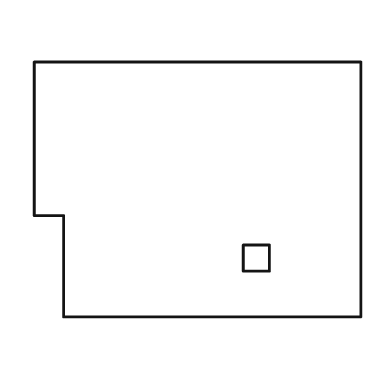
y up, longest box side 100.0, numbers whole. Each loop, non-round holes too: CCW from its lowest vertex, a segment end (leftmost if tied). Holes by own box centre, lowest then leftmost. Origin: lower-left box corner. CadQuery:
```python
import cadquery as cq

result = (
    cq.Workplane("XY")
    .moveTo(9.0, 0.0)
    .lineTo(100.0, 0.0)
    .lineTo(100.0, 78.0)
    .lineTo(0.0, 78.0)
    .lineTo(0.0, 31.0)
    .lineTo(9.0, 31.0)
    .close()
    .moveTo(64.0, 14.0)
    .lineTo(72.0, 14.0)
    .lineTo(72.0, 22.0)
    .lineTo(64.0, 22.0)
    .close()
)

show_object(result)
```